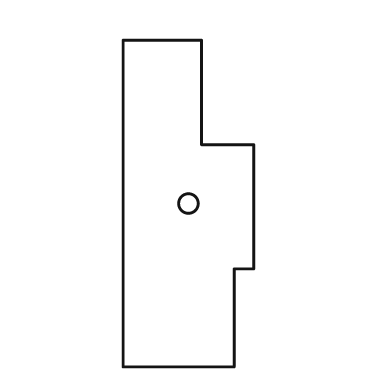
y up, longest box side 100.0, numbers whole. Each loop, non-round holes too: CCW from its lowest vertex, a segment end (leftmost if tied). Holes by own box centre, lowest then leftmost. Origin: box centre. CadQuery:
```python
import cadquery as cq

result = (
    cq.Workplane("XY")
    .moveTo(-20.0, -50.0)
    .lineTo(14.0, -50.0)
    .lineTo(14.0, -20.0)
    .lineTo(20.0, -20.0)
    .lineTo(20.0, 18.0)
    .lineTo(4.0, 18.0)
    .lineTo(4.0, 50.0)
    .lineTo(-20.0, 50.0)
    .close()
    .moveTo(0.0, 0.0)
    .circle(3.0)
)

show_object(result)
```